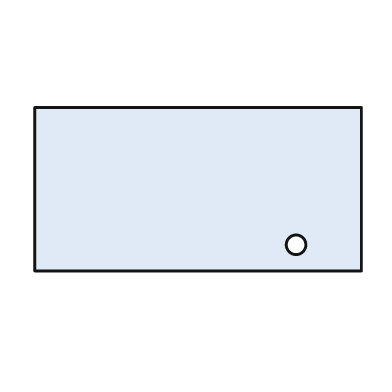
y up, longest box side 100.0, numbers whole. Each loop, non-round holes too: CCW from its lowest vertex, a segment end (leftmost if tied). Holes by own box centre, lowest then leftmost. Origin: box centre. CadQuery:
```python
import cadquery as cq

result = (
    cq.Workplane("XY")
    .moveTo(-50.0, -25.0)
    .lineTo(50.0, -25.0)
    .lineTo(50.0, 25.0)
    .lineTo(-50.0, 25.0)
    .close()
    .moveTo(30.0, -17.0)
    .circle(3.0)
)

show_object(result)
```